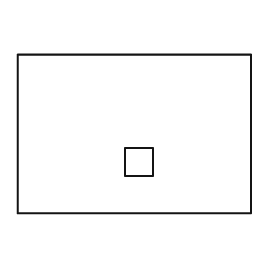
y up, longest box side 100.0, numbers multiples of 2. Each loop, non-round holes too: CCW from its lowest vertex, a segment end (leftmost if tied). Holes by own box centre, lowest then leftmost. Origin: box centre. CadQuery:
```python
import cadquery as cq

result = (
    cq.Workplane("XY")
    .moveTo(-50.0, -34.0)
    .lineTo(50.0, -34.0)
    .lineTo(50.0, 34.0)
    .lineTo(-50.0, 34.0)
    .close()
    .moveTo(-4.0, -18.0)
    .lineTo(8.0, -18.0)
    .lineTo(8.0, -6.0)
    .lineTo(-4.0, -6.0)
    .close()
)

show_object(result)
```